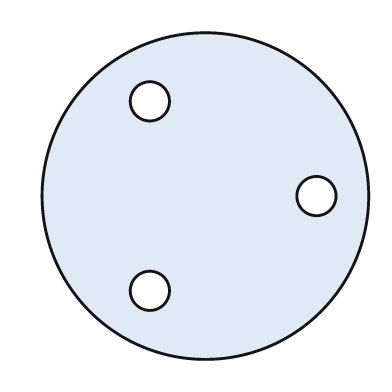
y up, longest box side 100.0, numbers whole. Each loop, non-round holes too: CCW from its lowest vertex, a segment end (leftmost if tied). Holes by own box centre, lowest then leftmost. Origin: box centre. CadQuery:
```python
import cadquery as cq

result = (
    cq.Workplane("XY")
    .moveTo(0.0, 0.0)
    .circle(50.0)
    .moveTo(-17.0, -29.0)
    .circle(6.0)
    .moveTo(34.0, 0.0)
    .circle(6.0)
    .moveTo(-17.0, 29.0)
    .circle(6.0)
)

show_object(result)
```